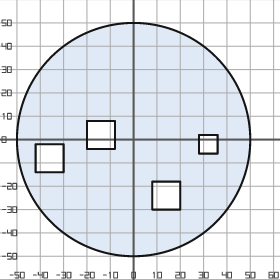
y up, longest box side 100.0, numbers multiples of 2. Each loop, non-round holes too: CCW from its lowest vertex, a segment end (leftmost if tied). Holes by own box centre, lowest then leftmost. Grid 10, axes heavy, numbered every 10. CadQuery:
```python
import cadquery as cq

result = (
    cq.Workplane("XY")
    .moveTo(0.0, 0.0)
    .circle(50.0)
    .moveTo(8.0, -30.0)
    .lineTo(20.0, -30.0)
    .lineTo(20.0, -18.0)
    .lineTo(8.0, -18.0)
    .close()
    .moveTo(-42.0, -14.0)
    .lineTo(-30.0, -14.0)
    .lineTo(-30.0, -2.0)
    .lineTo(-42.0, -2.0)
    .close()
    .moveTo(28.0, -6.0)
    .lineTo(36.0, -6.0)
    .lineTo(36.0, 2.0)
    .lineTo(28.0, 2.0)
    .close()
    .moveTo(-20.0, -4.0)
    .lineTo(-8.0, -4.0)
    .lineTo(-8.0, 8.0)
    .lineTo(-20.0, 8.0)
    .close()
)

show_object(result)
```